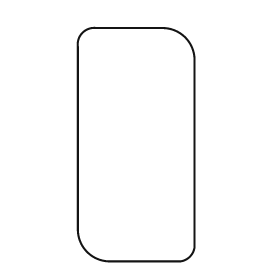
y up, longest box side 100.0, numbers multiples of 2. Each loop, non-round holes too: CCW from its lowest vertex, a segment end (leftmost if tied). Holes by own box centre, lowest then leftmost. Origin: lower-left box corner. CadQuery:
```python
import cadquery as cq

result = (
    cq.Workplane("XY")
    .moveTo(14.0, 0.0)
    .lineTo(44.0, 0.0)
    .threePointArc((48.0, 2.0), (50.0, 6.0))
    .lineTo(50.0, 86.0)
    .threePointArc((46.0, 96.0), (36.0, 100.0))
    .lineTo(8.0, 100.0)
    .threePointArc((2.0, 98.0), (0.0, 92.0))
    .lineTo(0.0, 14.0)
    .threePointArc((4.0, 4.0), (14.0, 0.0))
    .close()
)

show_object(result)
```